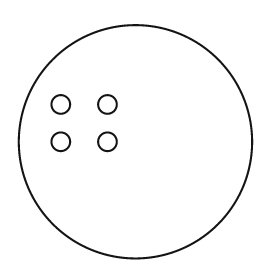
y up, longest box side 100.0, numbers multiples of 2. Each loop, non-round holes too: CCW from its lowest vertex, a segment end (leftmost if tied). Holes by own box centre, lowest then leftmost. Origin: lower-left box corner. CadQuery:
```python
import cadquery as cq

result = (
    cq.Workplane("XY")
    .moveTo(50.0, 50.0)
    .circle(50.0)
    .moveTo(18.0, 50.0)
    .circle(4.0)
    .moveTo(38.0, 50.0)
    .circle(4.0)
    .moveTo(18.0, 66.0)
    .circle(4.0)
    .moveTo(38.0, 66.0)
    .circle(4.0)
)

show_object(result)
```